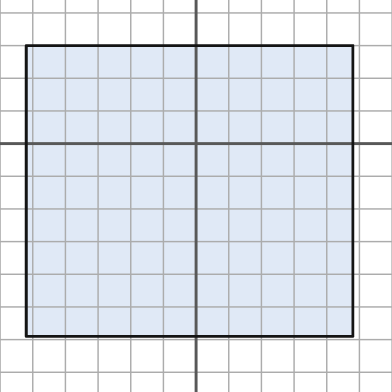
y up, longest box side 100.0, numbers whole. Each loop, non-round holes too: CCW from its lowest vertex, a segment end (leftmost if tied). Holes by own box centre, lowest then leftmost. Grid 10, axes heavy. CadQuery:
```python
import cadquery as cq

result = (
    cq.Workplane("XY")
    .moveTo(-52.0, -59.0)
    .lineTo(48.0, -59.0)
    .lineTo(48.0, 30.0)
    .lineTo(-52.0, 30.0)
    .close()
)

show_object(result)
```